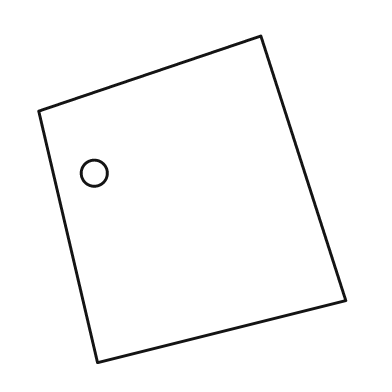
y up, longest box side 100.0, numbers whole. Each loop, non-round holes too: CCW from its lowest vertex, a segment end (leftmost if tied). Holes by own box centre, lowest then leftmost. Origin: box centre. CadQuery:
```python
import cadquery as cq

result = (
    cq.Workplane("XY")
    .moveTo(-29.0, -50.0)
    .lineTo(47.0, -31.0)
    .lineTo(21.0, 50.0)
    .lineTo(-47.0, 27.0)
    .close()
    .moveTo(-30.0, 8.0)
    .circle(4.0)
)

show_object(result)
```